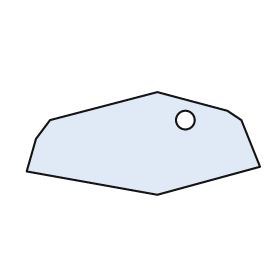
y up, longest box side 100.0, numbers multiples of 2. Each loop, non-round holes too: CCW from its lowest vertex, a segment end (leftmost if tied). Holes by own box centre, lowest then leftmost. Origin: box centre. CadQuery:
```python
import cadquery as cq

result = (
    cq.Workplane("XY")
    .moveTo(6.0, -22.0)
    .lineTo(50.0, -10.0)
    .lineTo(42.0, 10.0)
    .lineTo(36.0, 14.0)
    .lineTo(6.0, 22.0)
    .lineTo(-40.0, 10.0)
    .lineTo(-46.0, 2.0)
    .lineTo(-50.0, -12.0)
    .close()
    .moveTo(18.0, 10.0)
    .circle(4.0)
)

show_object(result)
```